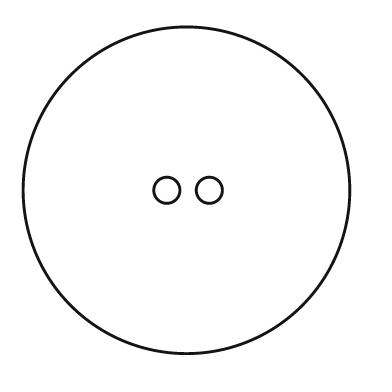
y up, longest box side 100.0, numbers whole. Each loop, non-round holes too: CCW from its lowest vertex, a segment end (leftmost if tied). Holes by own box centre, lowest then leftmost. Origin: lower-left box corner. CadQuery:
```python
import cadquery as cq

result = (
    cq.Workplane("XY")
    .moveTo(50.0, 50.0)
    .circle(50.0)
    .moveTo(44.0, 50.0)
    .circle(4.0)
    .moveTo(57.0, 50.0)
    .circle(4.0)
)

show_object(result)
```